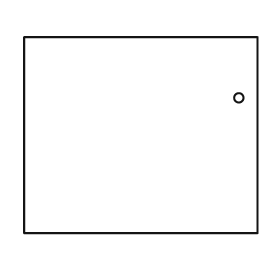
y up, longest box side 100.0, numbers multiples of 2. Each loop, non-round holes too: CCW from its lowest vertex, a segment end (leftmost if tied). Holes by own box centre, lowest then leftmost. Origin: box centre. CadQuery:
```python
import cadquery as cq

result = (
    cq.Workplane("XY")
    .moveTo(-50.0, -42.0)
    .lineTo(50.0, -42.0)
    .lineTo(50.0, 42.0)
    .lineTo(-50.0, 42.0)
    .close()
    .moveTo(42.0, 16.0)
    .circle(2.0)
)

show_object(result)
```